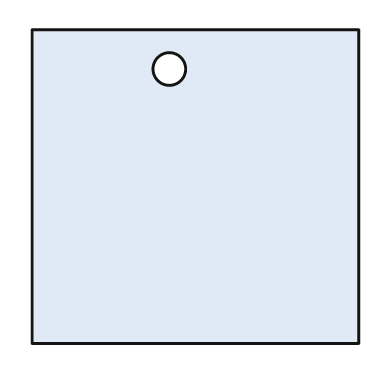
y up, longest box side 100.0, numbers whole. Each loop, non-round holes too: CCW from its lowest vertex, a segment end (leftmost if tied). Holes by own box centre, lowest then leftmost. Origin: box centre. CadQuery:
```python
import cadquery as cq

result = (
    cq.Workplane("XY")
    .moveTo(-50.0, -48.0)
    .lineTo(50.0, -48.0)
    .lineTo(50.0, 48.0)
    .lineTo(-50.0, 48.0)
    .close()
    .moveTo(-8.0, 36.0)
    .circle(5.0)
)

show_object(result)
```